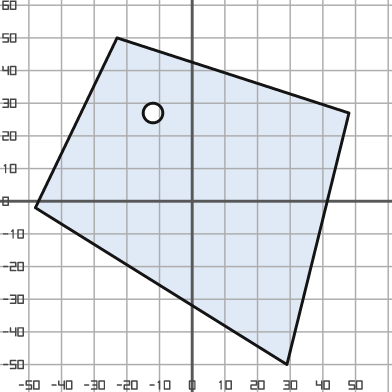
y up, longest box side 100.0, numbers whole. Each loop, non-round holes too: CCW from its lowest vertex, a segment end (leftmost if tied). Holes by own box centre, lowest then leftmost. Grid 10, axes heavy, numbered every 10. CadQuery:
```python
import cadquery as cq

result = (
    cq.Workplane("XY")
    .moveTo(29.0, -50.0)
    .lineTo(48.0, 27.0)
    .lineTo(-23.0, 50.0)
    .lineTo(-48.0, -2.0)
    .close()
    .moveTo(-12.0, 27.0)
    .circle(3.0)
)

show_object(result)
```